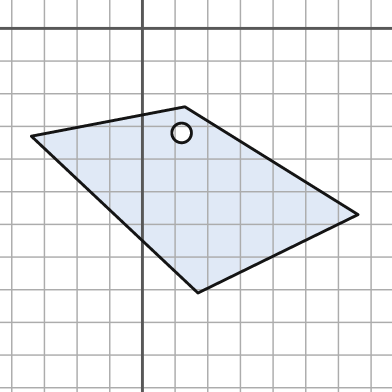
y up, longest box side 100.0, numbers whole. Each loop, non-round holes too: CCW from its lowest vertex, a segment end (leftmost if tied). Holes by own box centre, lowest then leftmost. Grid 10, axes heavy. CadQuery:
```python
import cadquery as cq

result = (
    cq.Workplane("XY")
    .moveTo(17.0, -81.0)
    .lineTo(66.0, -57.0)
    .lineTo(13.0, -24.0)
    .lineTo(-34.0, -33.0)
    .close()
    .moveTo(12.0, -32.0)
    .circle(3.0)
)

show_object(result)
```